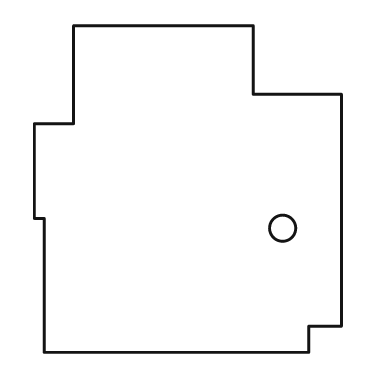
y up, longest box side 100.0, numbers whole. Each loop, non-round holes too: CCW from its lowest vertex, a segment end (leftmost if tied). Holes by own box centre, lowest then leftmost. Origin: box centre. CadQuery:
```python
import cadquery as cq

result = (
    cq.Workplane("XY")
    .moveTo(-44.0, -50.0)
    .lineTo(37.0, -50.0)
    .lineTo(37.0, -42.0)
    .lineTo(47.0, -42.0)
    .lineTo(47.0, 29.0)
    .lineTo(20.0, 29.0)
    .lineTo(20.0, 50.0)
    .lineTo(-35.0, 50.0)
    .lineTo(-35.0, 20.0)
    .lineTo(-47.0, 20.0)
    .lineTo(-47.0, -9.0)
    .lineTo(-44.0, -9.0)
    .close()
    .moveTo(29.0, -12.0)
    .circle(4.0)
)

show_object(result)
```